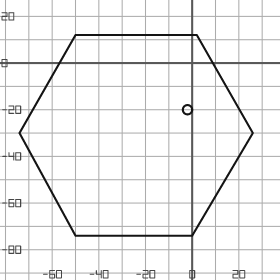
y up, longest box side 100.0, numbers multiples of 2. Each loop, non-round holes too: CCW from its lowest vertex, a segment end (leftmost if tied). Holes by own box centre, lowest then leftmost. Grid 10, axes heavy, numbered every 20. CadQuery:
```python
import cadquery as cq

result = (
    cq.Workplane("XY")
    .moveTo(-50.0, -74.0)
    .lineTo(0.0, -74.0)
    .lineTo(26.0, -30.0)
    .lineTo(2.0, 12.0)
    .lineTo(-50.0, 12.0)
    .lineTo(-74.0, -30.0)
    .close()
    .moveTo(-2.0, -20.0)
    .circle(2.0)
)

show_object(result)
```